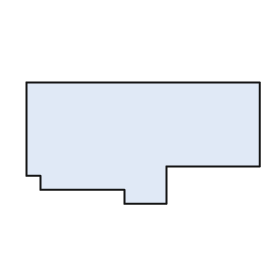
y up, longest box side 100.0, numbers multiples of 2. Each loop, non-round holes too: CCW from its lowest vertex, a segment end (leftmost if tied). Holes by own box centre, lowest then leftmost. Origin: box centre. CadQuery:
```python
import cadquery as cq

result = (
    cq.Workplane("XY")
    .moveTo(-8.0, -26.0)
    .lineTo(10.0, -26.0)
    .lineTo(10.0, -10.0)
    .lineTo(50.0, -10.0)
    .lineTo(50.0, 26.0)
    .lineTo(-50.0, 26.0)
    .lineTo(-50.0, -14.0)
    .lineTo(-44.0, -14.0)
    .lineTo(-44.0, -20.0)
    .lineTo(-8.0, -20.0)
    .close()
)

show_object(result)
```